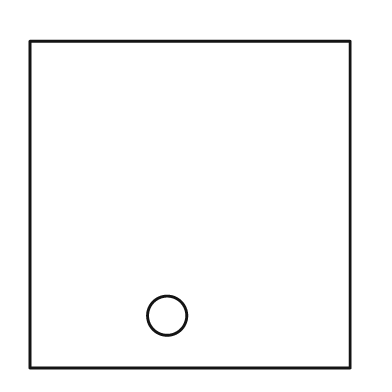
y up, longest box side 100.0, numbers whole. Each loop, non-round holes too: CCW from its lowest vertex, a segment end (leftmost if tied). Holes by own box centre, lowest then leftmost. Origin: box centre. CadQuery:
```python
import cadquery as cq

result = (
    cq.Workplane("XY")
    .moveTo(-49.0, -50.0)
    .lineTo(49.0, -50.0)
    .lineTo(49.0, 50.0)
    .lineTo(-49.0, 50.0)
    .close()
    .moveTo(-7.0, -34.0)
    .circle(6.0)
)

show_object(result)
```